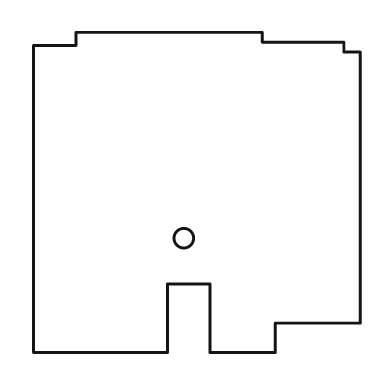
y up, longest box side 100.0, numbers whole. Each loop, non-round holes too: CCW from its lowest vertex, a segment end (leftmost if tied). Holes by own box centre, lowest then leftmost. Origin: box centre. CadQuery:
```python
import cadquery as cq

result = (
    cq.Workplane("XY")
    .moveTo(-50.0, -49.0)
    .lineTo(-9.0, -49.0)
    .lineTo(-9.0, -28.0)
    .lineTo(4.0, -28.0)
    .lineTo(4.0, -49.0)
    .lineTo(24.0, -49.0)
    .lineTo(24.0, -40.0)
    .lineTo(50.0, -40.0)
    .lineTo(50.0, 43.0)
    .lineTo(45.0, 43.0)
    .lineTo(45.0, 46.0)
    .lineTo(20.0, 46.0)
    .lineTo(20.0, 49.0)
    .lineTo(-37.0, 49.0)
    .lineTo(-37.0, 45.0)
    .lineTo(-50.0, 45.0)
    .close()
    .moveTo(-4.0, -14.0)
    .circle(3.0)
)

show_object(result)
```